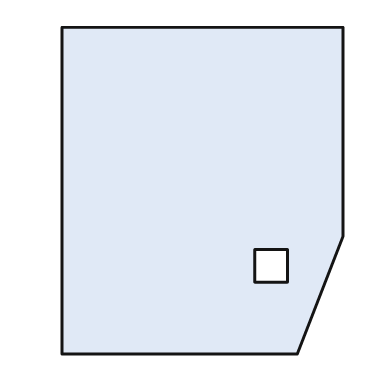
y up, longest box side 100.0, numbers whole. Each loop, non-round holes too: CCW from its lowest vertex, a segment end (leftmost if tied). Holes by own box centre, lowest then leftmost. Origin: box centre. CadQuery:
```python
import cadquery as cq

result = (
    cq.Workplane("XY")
    .moveTo(-43.0, -50.0)
    .lineTo(29.0, -50.0)
    .lineTo(43.0, -14.0)
    .lineTo(43.0, 50.0)
    .lineTo(-43.0, 50.0)
    .close()
    .moveTo(16.0, -28.0)
    .lineTo(26.0, -28.0)
    .lineTo(26.0, -18.0)
    .lineTo(16.0, -18.0)
    .close()
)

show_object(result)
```